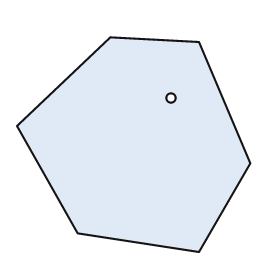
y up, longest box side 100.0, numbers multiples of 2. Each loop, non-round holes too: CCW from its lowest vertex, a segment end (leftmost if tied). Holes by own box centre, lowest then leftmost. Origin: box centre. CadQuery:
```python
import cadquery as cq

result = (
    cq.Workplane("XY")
    .moveTo(28.0, -46.0)
    .lineTo(50.0, -8.0)
    .lineTo(28.0, 44.0)
    .lineTo(-10.0, 46.0)
    .lineTo(-50.0, 8.0)
    .lineTo(-24.0, -38.0)
    .close()
    .moveTo(16.0, 20.0)
    .circle(2.0)
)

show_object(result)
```